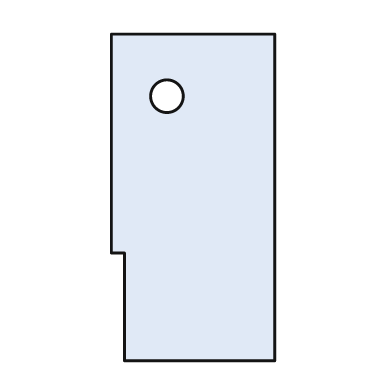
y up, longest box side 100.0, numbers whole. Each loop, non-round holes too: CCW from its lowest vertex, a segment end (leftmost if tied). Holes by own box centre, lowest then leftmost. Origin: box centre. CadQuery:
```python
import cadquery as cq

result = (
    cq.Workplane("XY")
    .moveTo(-21.0, -50.0)
    .lineTo(25.0, -50.0)
    .lineTo(25.0, 50.0)
    .lineTo(-25.0, 50.0)
    .lineTo(-25.0, -17.0)
    .lineTo(-21.0, -17.0)
    .close()
    .moveTo(-8.0, 31.0)
    .circle(5.0)
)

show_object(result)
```